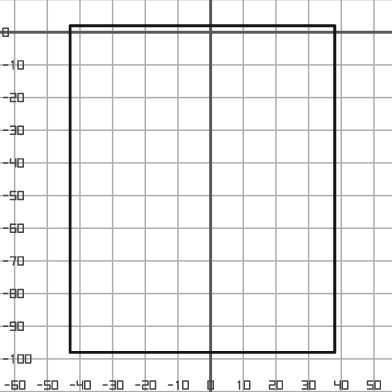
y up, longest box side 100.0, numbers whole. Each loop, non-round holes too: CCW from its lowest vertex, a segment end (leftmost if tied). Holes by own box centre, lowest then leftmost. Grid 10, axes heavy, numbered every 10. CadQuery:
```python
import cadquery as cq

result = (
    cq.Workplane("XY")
    .moveTo(-43.0, -98.0)
    .lineTo(38.0, -98.0)
    .lineTo(38.0, 2.0)
    .lineTo(-43.0, 2.0)
    .close()
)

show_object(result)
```